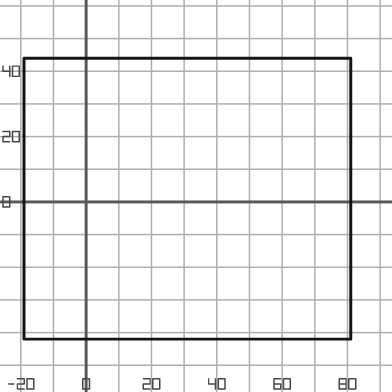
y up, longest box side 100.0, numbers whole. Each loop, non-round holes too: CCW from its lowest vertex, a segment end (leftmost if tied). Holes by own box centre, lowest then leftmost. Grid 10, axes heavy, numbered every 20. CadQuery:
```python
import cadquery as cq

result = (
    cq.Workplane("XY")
    .moveTo(-19.0, -42.0)
    .lineTo(81.0, -42.0)
    .lineTo(81.0, 44.0)
    .lineTo(-19.0, 44.0)
    .close()
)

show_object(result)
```